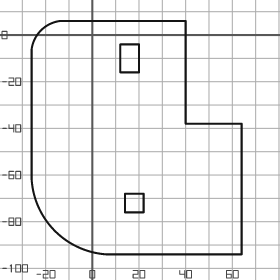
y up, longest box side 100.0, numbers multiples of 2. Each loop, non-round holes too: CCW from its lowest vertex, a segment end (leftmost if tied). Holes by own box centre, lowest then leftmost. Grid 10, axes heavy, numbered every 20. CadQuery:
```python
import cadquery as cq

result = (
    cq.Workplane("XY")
    .moveTo(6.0, -94.0)
    .lineTo(64.0, -94.0)
    .lineTo(64.0, -38.0)
    .lineTo(40.0, -38.0)
    .lineTo(40.0, 6.0)
    .lineTo(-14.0, 6.0)
    .threePointArc((-22.0, 2.0), (-26.0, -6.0))
    .lineTo(-26.0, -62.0)
    .threePointArc((-16.0, -84.0), (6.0, -94.0))
    .close()
    .moveTo(14.0, -76.0)
    .lineTo(22.0, -76.0)
    .lineTo(22.0, -68.0)
    .lineTo(14.0, -68.0)
    .close()
    .moveTo(12.0, -16.0)
    .lineTo(20.0, -16.0)
    .lineTo(20.0, -4.0)
    .lineTo(12.0, -4.0)
    .close()
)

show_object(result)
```